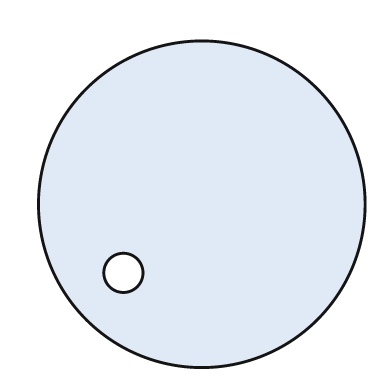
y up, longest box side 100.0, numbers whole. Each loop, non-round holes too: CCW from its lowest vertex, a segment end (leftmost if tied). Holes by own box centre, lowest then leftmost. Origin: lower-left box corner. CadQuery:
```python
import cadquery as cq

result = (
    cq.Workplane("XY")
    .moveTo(50.0, 50.0)
    .circle(50.0)
    .moveTo(26.0, 29.0)
    .circle(6.0)
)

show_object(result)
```